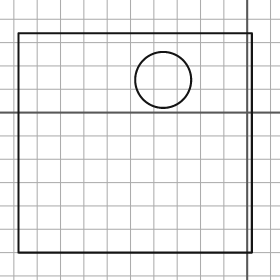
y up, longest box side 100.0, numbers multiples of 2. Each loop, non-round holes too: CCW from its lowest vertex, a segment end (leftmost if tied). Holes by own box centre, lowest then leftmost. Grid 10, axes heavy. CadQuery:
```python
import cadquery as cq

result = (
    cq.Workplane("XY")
    .moveTo(-98.0, -60.0)
    .lineTo(2.0, -60.0)
    .lineTo(2.0, 34.0)
    .lineTo(-98.0, 34.0)
    .close()
    .moveTo(-36.0, 14.0)
    .circle(12.0)
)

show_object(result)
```